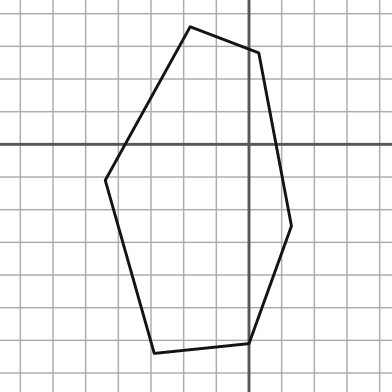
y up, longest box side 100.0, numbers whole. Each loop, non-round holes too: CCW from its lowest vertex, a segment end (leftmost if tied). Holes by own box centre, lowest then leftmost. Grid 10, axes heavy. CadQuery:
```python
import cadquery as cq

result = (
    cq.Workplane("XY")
    .moveTo(-29.0, -64.0)
    .lineTo(0.0, -61.0)
    .lineTo(13.0, -25.0)
    .lineTo(3.0, 28.0)
    .lineTo(-18.0, 36.0)
    .lineTo(-44.0, -11.0)
    .close()
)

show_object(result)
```